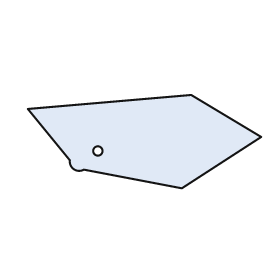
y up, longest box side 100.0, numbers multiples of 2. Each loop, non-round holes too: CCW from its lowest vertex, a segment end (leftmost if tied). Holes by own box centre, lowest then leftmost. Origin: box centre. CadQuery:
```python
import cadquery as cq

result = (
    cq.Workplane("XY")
    .moveTo(16.0, -20.0)
    .lineTo(50.0, 2.0)
    .lineTo(20.0, 20.0)
    .lineTo(-50.0, 14.0)
    .lineTo(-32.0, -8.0)
    .threePointArc((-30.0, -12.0), (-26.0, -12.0))
    .close()
    .moveTo(-20.0, -4.0)
    .circle(2.0)
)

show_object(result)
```